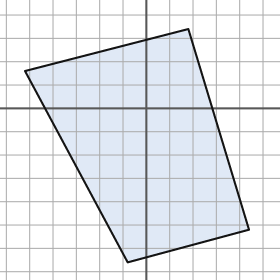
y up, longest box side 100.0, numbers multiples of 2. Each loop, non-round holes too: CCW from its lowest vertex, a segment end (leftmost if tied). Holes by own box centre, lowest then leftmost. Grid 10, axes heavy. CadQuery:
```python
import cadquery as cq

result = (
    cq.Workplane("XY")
    .moveTo(-8.0, -66.0)
    .lineTo(44.0, -52.0)
    .lineTo(18.0, 34.0)
    .lineTo(-52.0, 16.0)
    .close()
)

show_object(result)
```